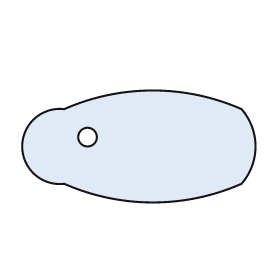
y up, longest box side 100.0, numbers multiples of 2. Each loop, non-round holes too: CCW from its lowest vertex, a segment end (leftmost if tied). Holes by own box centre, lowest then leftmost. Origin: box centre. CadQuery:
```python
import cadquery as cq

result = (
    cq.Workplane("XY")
    .moveTo(-32.0, -16.0)
    .threePointArc((6.0, -24.0), (44.0, -16.0))
    .threePointArc((50.0, 0.0), (44.0, 16.0))
    .threePointArc((6.0, 24.0), (-32.0, 16.0))
    .threePointArc((-50.0, 0.0), (-32.0, -16.0))
    .close()
    .moveTo(-22.0, 4.0)
    .circle(4.0)
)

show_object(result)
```